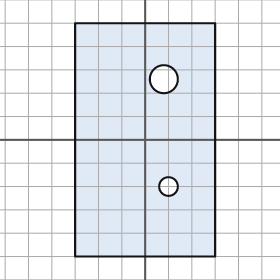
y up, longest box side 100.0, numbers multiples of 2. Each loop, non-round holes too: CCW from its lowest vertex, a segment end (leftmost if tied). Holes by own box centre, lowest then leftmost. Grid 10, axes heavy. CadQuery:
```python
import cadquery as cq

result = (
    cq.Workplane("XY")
    .moveTo(-30.0, -50.0)
    .lineTo(30.0, -50.0)
    .lineTo(30.0, 50.0)
    .lineTo(-30.0, 50.0)
    .close()
    .moveTo(10.0, -20.0)
    .circle(4.0)
    .moveTo(8.0, 26.0)
    .circle(6.0)
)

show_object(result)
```